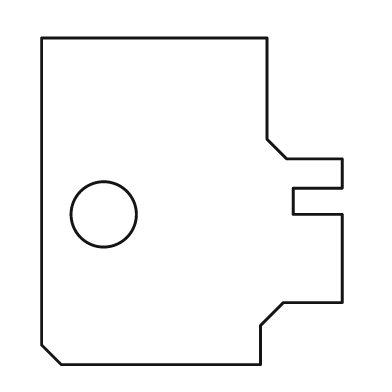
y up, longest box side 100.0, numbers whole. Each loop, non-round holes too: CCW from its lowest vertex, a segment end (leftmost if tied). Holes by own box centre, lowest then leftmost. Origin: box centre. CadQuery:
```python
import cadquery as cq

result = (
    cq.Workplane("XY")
    .moveTo(-40.0, -50.0)
    .lineTo(21.0, -50.0)
    .lineTo(21.0, -38.0)
    .lineTo(28.0, -31.0)
    .lineTo(46.0, -31.0)
    .lineTo(46.0, -4.0)
    .lineTo(31.0, -4.0)
    .lineTo(31.0, 4.0)
    .lineTo(46.0, 4.0)
    .lineTo(46.0, 13.0)
    .lineTo(29.0, 13.0)
    .lineTo(23.0, 19.0)
    .lineTo(23.0, 50.0)
    .lineTo(-46.0, 50.0)
    .lineTo(-46.0, -44.0)
    .close()
    .moveTo(-27.0, -4.0)
    .circle(10.0)
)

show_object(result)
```